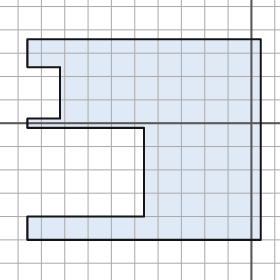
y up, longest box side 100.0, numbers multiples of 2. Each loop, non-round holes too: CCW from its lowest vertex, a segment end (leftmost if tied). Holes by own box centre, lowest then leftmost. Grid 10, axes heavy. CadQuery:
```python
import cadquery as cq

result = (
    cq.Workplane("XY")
    .moveTo(-96.0, -50.0)
    .lineTo(4.0, -50.0)
    .lineTo(4.0, 36.0)
    .lineTo(-96.0, 36.0)
    .lineTo(-96.0, 24.0)
    .lineTo(-82.0, 24.0)
    .lineTo(-82.0, 2.0)
    .lineTo(-96.0, 2.0)
    .lineTo(-96.0, -2.0)
    .lineTo(-46.0, -2.0)
    .lineTo(-46.0, -40.0)
    .lineTo(-96.0, -40.0)
    .close()
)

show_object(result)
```